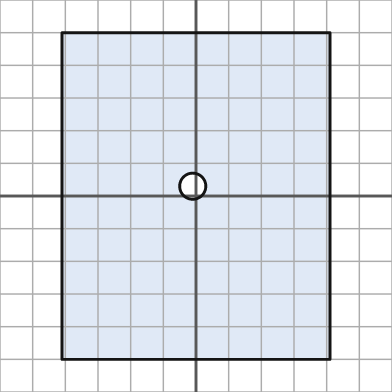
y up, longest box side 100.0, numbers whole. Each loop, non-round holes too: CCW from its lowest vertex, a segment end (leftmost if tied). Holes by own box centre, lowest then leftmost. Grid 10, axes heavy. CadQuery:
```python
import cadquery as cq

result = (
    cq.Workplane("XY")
    .moveTo(-41.0, -50.0)
    .lineTo(41.0, -50.0)
    .lineTo(41.0, 50.0)
    .lineTo(-41.0, 50.0)
    .close()
    .moveTo(-1.0, 3.0)
    .circle(4.0)
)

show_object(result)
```